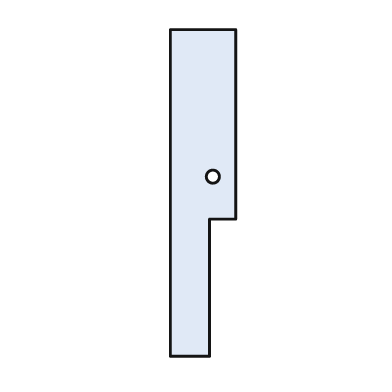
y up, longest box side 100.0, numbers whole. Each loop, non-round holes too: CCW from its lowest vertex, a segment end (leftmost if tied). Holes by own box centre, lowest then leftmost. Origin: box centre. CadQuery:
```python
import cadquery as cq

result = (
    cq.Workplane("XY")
    .moveTo(-10.0, -50.0)
    .lineTo(2.0, -50.0)
    .lineTo(2.0, -8.0)
    .lineTo(10.0, -8.0)
    .lineTo(10.0, 50.0)
    .lineTo(-10.0, 50.0)
    .close()
    .moveTo(3.0, 5.0)
    .circle(2.0)
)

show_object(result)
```